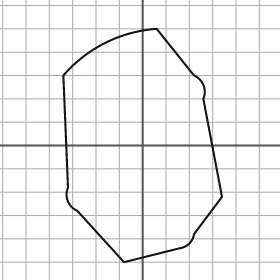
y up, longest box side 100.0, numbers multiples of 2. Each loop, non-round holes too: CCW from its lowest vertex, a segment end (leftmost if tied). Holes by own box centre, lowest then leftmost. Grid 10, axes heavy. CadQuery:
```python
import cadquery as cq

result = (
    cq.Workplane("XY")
    .moveTo(-8.0, -50.0)
    .lineTo(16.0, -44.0)
    .threePointArc((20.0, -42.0), (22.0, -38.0))
    .lineTo(34.0, -22.0)
    .lineTo(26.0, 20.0)
    .threePointArc((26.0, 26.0), (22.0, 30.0))
    .lineTo(6.0, 50.0)
    .threePointArc((-16.0, 44.0), (-34.0, 30.0))
    .lineTo(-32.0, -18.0)
    .threePointArc((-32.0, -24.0), (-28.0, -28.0))
    .close()
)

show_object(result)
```